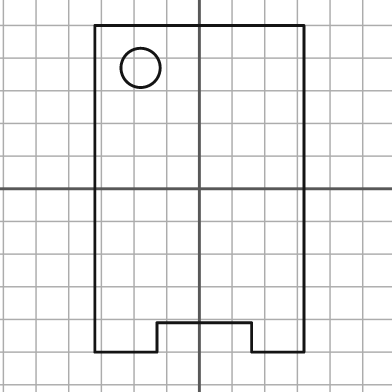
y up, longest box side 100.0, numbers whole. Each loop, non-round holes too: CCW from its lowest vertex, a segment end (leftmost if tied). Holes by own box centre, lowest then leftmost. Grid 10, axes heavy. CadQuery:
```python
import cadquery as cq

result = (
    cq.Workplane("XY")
    .moveTo(-32.0, -50.0)
    .lineTo(-13.0, -50.0)
    .lineTo(-13.0, -41.0)
    .lineTo(16.0, -41.0)
    .lineTo(16.0, -50.0)
    .lineTo(32.0, -50.0)
    .lineTo(32.0, 50.0)
    .lineTo(-32.0, 50.0)
    .close()
    .moveTo(-18.0, 37.0)
    .circle(6.0)
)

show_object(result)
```